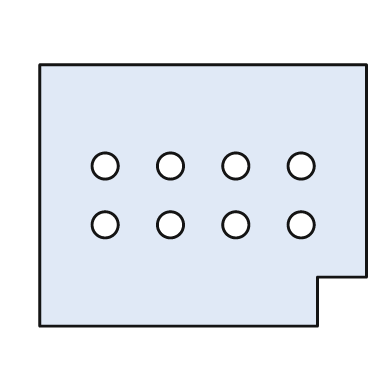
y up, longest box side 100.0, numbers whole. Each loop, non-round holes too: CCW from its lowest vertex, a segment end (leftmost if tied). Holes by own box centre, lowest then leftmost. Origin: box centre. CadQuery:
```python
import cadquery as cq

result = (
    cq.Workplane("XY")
    .moveTo(-50.0, -40.0)
    .lineTo(35.0, -40.0)
    .lineTo(35.0, -25.0)
    .lineTo(50.0, -25.0)
    .lineTo(50.0, 40.0)
    .lineTo(-50.0, 40.0)
    .close()
    .moveTo(-30.0, -9.0)
    .circle(4.0)
    .moveTo(-10.0, -9.0)
    .circle(4.0)
    .moveTo(10.0, -9.0)
    .circle(4.0)
    .moveTo(30.0, -9.0)
    .circle(4.0)
    .moveTo(-30.0, 9.0)
    .circle(4.0)
    .moveTo(-10.0, 9.0)
    .circle(4.0)
    .moveTo(10.0, 9.0)
    .circle(4.0)
    .moveTo(30.0, 9.0)
    .circle(4.0)
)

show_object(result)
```